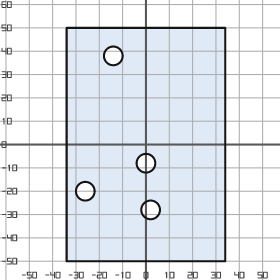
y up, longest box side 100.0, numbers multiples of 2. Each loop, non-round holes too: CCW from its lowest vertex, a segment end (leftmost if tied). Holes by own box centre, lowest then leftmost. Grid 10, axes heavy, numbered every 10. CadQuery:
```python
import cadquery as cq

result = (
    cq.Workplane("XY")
    .moveTo(-34.0, -50.0)
    .lineTo(34.0, -50.0)
    .lineTo(34.0, 50.0)
    .lineTo(-34.0, 50.0)
    .close()
    .moveTo(2.0, -28.0)
    .circle(4.0)
    .moveTo(-26.0, -20.0)
    .circle(4.0)
    .moveTo(0.0, -8.0)
    .circle(4.0)
    .moveTo(-14.0, 38.0)
    .circle(4.0)
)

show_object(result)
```